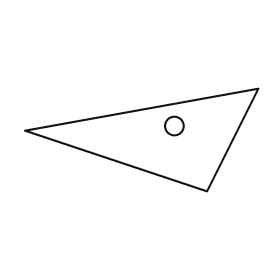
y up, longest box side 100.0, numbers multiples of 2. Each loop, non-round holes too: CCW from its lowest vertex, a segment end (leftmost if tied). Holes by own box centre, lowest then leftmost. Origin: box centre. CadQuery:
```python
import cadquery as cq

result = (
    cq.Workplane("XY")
    .moveTo(28.0, -22.0)
    .lineTo(50.0, 22.0)
    .lineTo(-50.0, 4.0)
    .close()
    .moveTo(14.0, 6.0)
    .circle(4.0)
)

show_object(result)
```